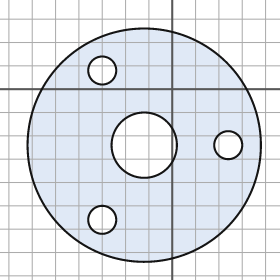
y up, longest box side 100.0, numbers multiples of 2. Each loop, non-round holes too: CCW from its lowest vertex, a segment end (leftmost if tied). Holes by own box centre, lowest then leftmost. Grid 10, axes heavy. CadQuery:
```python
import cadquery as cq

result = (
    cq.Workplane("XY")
    .moveTo(-12.0, -24.0)
    .circle(50.0)
    .moveTo(-30.0, -56.0)
    .circle(6.0)
    .moveTo(-12.0, -24.0)
    .circle(14.0)
    .moveTo(24.0, -24.0)
    .circle(6.0)
    .moveTo(-30.0, 8.0)
    .circle(6.0)
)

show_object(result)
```